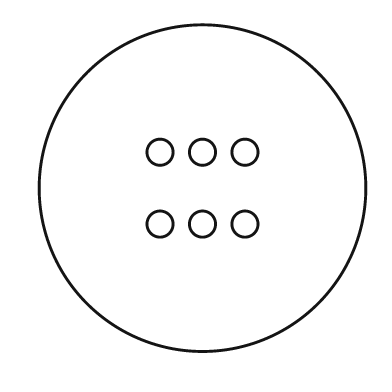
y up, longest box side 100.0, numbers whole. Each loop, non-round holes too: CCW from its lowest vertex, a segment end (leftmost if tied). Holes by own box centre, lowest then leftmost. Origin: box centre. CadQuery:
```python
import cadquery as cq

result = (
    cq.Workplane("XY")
    .moveTo(0.0, 0.0)
    .circle(50.0)
    .moveTo(-13.0, -11.0)
    .circle(4.0)
    .moveTo(0.0, -11.0)
    .circle(4.0)
    .moveTo(13.0, -11.0)
    .circle(4.0)
    .moveTo(-13.0, 11.0)
    .circle(4.0)
    .moveTo(0.0, 11.0)
    .circle(4.0)
    .moveTo(13.0, 11.0)
    .circle(4.0)
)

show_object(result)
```